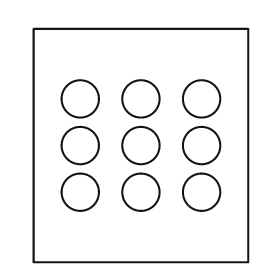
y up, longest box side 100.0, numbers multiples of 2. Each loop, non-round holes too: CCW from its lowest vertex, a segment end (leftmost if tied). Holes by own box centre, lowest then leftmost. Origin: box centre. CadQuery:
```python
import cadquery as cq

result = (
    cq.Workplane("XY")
    .moveTo(-46.0, -50.0)
    .lineTo(46.0, -50.0)
    .lineTo(46.0, 50.0)
    .lineTo(-46.0, 50.0)
    .close()
    .moveTo(-26.0, -20.0)
    .circle(8.0)
    .moveTo(0.0, -20.0)
    .circle(8.0)
    .moveTo(26.0, -20.0)
    .circle(8.0)
    .moveTo(-26.0, 0.0)
    .circle(8.0)
    .moveTo(0.0, 0.0)
    .circle(8.0)
    .moveTo(26.0, 0.0)
    .circle(8.0)
    .moveTo(-26.0, 20.0)
    .circle(8.0)
    .moveTo(0.0, 20.0)
    .circle(8.0)
    .moveTo(26.0, 20.0)
    .circle(8.0)
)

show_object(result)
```